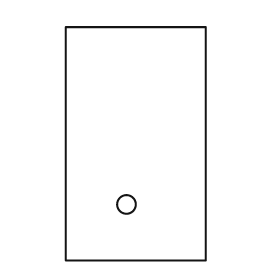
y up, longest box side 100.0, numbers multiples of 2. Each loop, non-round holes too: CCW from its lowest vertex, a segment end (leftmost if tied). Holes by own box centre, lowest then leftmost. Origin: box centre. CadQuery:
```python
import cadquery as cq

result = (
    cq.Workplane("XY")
    .moveTo(-30.0, -50.0)
    .lineTo(30.0, -50.0)
    .lineTo(30.0, 50.0)
    .lineTo(-30.0, 50.0)
    .close()
    .moveTo(-4.0, -26.0)
    .circle(4.0)
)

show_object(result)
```